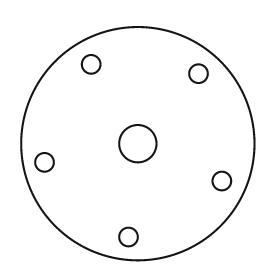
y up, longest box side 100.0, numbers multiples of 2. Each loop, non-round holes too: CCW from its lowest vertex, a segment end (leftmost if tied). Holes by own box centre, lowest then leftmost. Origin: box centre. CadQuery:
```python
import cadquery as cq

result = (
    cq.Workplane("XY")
    .moveTo(0.0, 0.0)
    .circle(50.0)
    .moveTo(-4.0, -40.0)
    .circle(4.0)
    .moveTo(36.0, -16.0)
    .circle(4.0)
    .moveTo(-40.0, -8.0)
    .circle(4.0)
    .moveTo(0.0, 0.0)
    .circle(8.0)
    .moveTo(26.0, 30.0)
    .circle(4.0)
    .moveTo(-20.0, 34.0)
    .circle(4.0)
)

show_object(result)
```